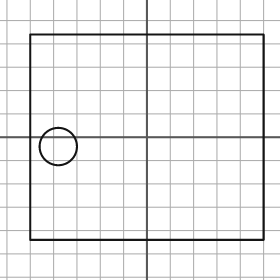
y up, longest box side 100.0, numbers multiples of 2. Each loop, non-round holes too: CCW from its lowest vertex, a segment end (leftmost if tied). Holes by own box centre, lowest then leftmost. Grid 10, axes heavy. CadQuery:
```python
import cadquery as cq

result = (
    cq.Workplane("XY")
    .moveTo(-50.0, -44.0)
    .lineTo(50.0, -44.0)
    .lineTo(50.0, 44.0)
    .lineTo(-50.0, 44.0)
    .close()
    .moveTo(-38.0, -4.0)
    .circle(8.0)
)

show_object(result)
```